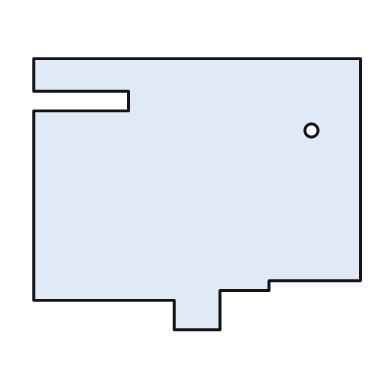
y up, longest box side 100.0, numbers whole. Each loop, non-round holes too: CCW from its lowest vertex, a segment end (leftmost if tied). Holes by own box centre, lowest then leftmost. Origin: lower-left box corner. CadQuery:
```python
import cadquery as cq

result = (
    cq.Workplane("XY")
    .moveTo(43.0, 0.0)
    .lineTo(57.0, 0.0)
    .lineTo(57.0, 12.0)
    .lineTo(72.0, 12.0)
    .lineTo(72.0, 15.0)
    .lineTo(100.0, 15.0)
    .lineTo(100.0, 83.0)
    .lineTo(0.0, 83.0)
    .lineTo(0.0, 73.0)
    .lineTo(29.0, 73.0)
    .lineTo(29.0, 67.0)
    .lineTo(0.0, 67.0)
    .lineTo(0.0, 9.0)
    .lineTo(43.0, 9.0)
    .close()
    .moveTo(85.0, 61.0)
    .circle(2.0)
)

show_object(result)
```